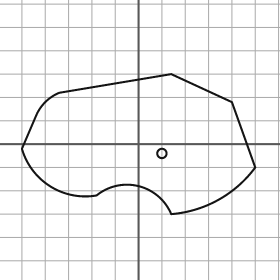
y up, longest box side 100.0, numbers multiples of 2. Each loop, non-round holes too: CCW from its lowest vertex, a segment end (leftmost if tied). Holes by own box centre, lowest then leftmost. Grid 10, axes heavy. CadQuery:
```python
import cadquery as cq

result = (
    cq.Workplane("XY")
    .moveTo(14.0, -30.0)
    .threePointArc((34.0, -24.0), (50.0, -10.0))
    .lineTo(40.0, 18.0)
    .lineTo(14.0, 30.0)
    .lineTo(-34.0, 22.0)
    .threePointArc((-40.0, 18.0), (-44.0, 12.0))
    .lineTo(-50.0, -2.0)
    .threePointArc((-38.0, -18.0), (-18.0, -22.0))
    .threePointArc((0.0, -18.0), (14.0, -30.0))
    .close()
    .moveTo(10.0, -4.0)
    .circle(2.0)
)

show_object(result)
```